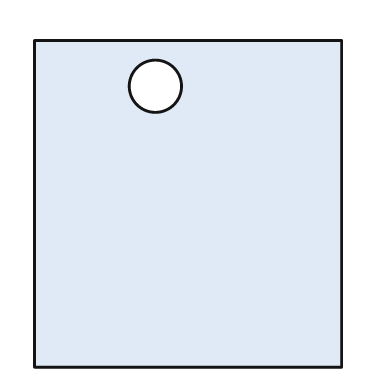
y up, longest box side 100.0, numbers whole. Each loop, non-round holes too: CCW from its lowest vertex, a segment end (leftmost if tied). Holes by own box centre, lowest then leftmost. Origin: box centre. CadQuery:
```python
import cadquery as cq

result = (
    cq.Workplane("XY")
    .moveTo(-47.0, -50.0)
    .lineTo(47.0, -50.0)
    .lineTo(47.0, 50.0)
    .lineTo(-47.0, 50.0)
    .close()
    .moveTo(-10.0, 36.0)
    .circle(8.0)
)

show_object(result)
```